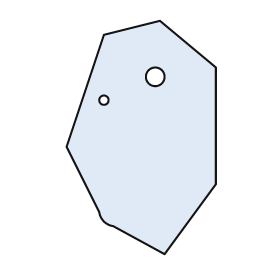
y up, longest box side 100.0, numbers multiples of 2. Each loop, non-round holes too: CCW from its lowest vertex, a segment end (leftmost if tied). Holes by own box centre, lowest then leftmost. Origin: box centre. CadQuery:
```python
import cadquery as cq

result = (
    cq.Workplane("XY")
    .moveTo(10.0, -50.0)
    .lineTo(32.0, -20.0)
    .lineTo(32.0, 30.0)
    .lineTo(8.0, 50.0)
    .lineTo(-16.0, 44.0)
    .lineTo(-32.0, -4.0)
    .lineTo(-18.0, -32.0)
    .threePointArc((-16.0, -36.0), (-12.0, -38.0))
    .close()
    .moveTo(-16.0, 16.0)
    .circle(2.0)
    .moveTo(6.0, 26.0)
    .circle(4.0)
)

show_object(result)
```